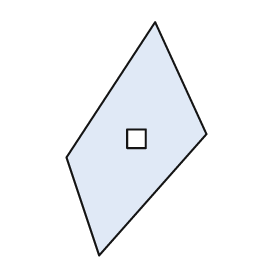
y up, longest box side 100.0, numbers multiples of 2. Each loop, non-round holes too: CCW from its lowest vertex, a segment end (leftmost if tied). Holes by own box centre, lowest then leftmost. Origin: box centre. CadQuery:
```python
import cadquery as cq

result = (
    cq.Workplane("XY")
    .moveTo(-16.0, -50.0)
    .lineTo(30.0, 2.0)
    .lineTo(8.0, 50.0)
    .lineTo(-30.0, -8.0)
    .close()
    .moveTo(-4.0, -4.0)
    .lineTo(4.0, -4.0)
    .lineTo(4.0, 4.0)
    .lineTo(-4.0, 4.0)
    .close()
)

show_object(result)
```